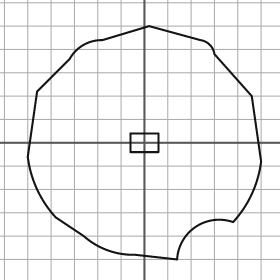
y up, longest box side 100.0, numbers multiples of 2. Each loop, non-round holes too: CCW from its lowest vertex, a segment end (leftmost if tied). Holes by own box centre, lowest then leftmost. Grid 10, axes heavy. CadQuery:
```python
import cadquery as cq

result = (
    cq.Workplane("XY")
    .moveTo(14.0, -50.0)
    .threePointArc((22.0, -36.0), (38.0, -34.0))
    .threePointArc((46.0, -22.0), (50.0, -8.0))
    .lineTo(46.0, 20.0)
    .lineTo(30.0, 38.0)
    .threePointArc((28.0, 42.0), (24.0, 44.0))
    .lineTo(2.0, 50.0)
    .lineTo(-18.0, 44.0)
    .threePointArc((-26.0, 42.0), (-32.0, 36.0))
    .lineTo(-46.0, 22.0)
    .lineTo(-50.0, -6.0)
    .threePointArc((-46.0, -20.0), (-38.0, -32.0))
    .lineTo(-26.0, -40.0)
    .threePointArc((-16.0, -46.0), (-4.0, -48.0))
    .close()
    .moveTo(-6.0, -4.0)
    .lineTo(6.0, -4.0)
    .lineTo(6.0, 4.0)
    .lineTo(-6.0, 4.0)
    .close()
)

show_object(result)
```